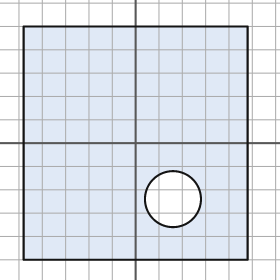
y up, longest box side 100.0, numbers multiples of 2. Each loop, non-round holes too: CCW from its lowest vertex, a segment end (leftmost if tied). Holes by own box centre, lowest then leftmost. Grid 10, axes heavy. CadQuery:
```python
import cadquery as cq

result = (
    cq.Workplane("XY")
    .moveTo(-48.0, -50.0)
    .lineTo(48.0, -50.0)
    .lineTo(48.0, 50.0)
    .lineTo(-48.0, 50.0)
    .close()
    .moveTo(16.0, -24.0)
    .circle(12.0)
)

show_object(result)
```